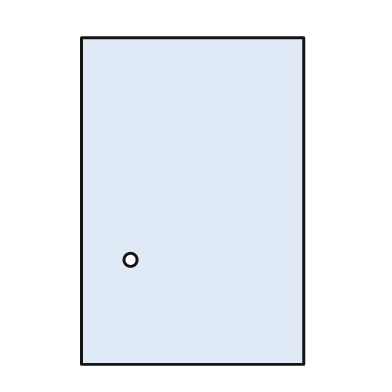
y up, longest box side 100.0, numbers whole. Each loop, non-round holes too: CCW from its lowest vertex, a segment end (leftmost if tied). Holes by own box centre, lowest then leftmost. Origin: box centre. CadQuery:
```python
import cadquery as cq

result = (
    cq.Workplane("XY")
    .moveTo(-34.0, -50.0)
    .lineTo(34.0, -50.0)
    .lineTo(34.0, 50.0)
    .lineTo(-34.0, 50.0)
    .close()
    .moveTo(-19.0, -18.0)
    .circle(2.0)
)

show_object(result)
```